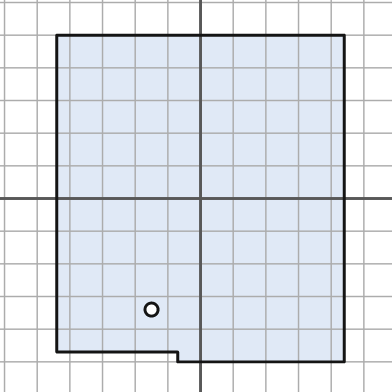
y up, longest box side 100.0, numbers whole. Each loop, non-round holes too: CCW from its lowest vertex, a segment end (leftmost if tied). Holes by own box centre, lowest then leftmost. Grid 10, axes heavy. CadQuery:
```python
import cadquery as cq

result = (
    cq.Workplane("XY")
    .moveTo(-7.0, -50.0)
    .lineTo(44.0, -50.0)
    .lineTo(44.0, 50.0)
    .lineTo(-44.0, 50.0)
    .lineTo(-44.0, -47.0)
    .lineTo(-7.0, -47.0)
    .close()
    .moveTo(-15.0, -34.0)
    .circle(2.0)
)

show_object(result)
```